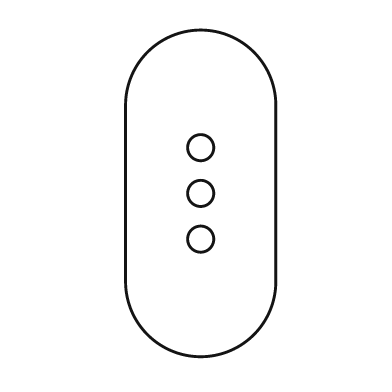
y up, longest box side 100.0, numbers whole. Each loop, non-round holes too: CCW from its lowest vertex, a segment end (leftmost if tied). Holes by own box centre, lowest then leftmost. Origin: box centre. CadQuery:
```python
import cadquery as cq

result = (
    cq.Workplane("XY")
    .moveTo(-23.0, -27.0)
    .threePointArc((0.0, -50.0), (23.0, -27.0))
    .lineTo(23.0, 27.0)
    .threePointArc((0.0, 50.0), (-23.0, 27.0))
    .close()
    .moveTo(0.0, -14.0)
    .circle(4.0)
    .moveTo(0.0, 0.0)
    .circle(4.0)
    .moveTo(0.0, 14.0)
    .circle(4.0)
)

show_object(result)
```